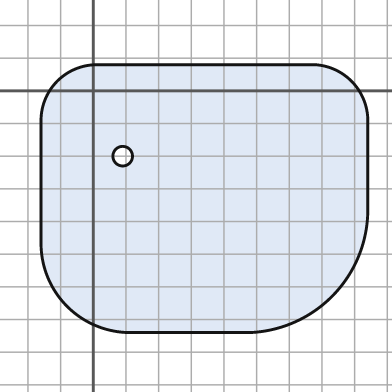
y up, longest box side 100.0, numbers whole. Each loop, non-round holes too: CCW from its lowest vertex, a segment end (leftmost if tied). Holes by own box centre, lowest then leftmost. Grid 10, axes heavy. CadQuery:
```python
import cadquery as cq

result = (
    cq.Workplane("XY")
    .moveTo(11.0, -74.0)
    .lineTo(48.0, -74.0)
    .threePointArc((73.0, -63.0), (84.0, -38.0))
    .lineTo(84.0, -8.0)
    .threePointArc((79.0, 3.0), (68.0, 8.0))
    .lineTo(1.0, 8.0)
    .threePointArc((-11.0, 3.0), (-16.0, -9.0))
    .lineTo(-16.0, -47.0)
    .threePointArc((-8.0, -66.0), (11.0, -74.0))
    .close()
    .moveTo(9.0, -20.0)
    .circle(3.0)
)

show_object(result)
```